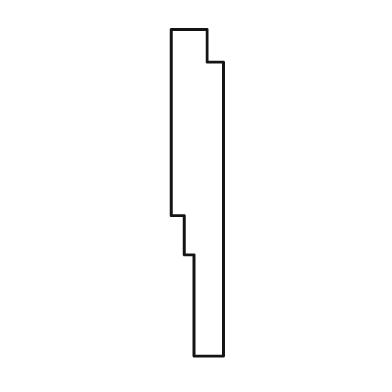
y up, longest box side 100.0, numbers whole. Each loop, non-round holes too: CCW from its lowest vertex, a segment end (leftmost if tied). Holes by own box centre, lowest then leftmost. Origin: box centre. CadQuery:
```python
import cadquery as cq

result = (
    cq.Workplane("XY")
    .moveTo(-1.0, -50.0)
    .lineTo(8.0, -50.0)
    .lineTo(8.0, 40.0)
    .lineTo(3.0, 40.0)
    .lineTo(3.0, 50.0)
    .lineTo(-8.0, 50.0)
    .lineTo(-8.0, -7.0)
    .lineTo(-4.0, -7.0)
    .lineTo(-4.0, -19.0)
    .lineTo(-1.0, -19.0)
    .close()
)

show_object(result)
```